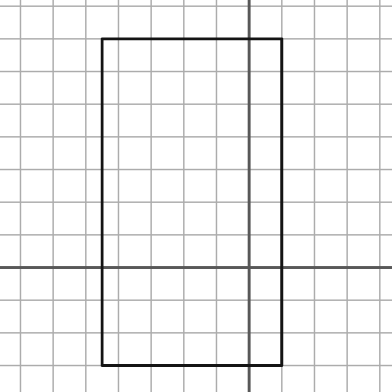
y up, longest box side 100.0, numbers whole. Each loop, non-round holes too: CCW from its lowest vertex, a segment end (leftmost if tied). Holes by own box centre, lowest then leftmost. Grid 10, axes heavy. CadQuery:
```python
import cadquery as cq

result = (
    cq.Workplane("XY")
    .moveTo(-45.0, -30.0)
    .lineTo(10.0, -30.0)
    .lineTo(10.0, 70.0)
    .lineTo(-45.0, 70.0)
    .close()
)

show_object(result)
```